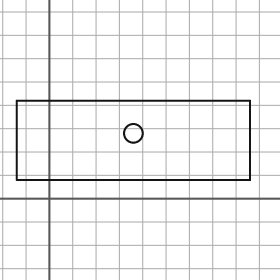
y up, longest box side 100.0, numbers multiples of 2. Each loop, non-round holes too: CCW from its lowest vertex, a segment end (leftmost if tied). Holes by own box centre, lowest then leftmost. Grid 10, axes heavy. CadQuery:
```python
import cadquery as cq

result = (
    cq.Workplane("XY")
    .moveTo(-14.0, 8.0)
    .lineTo(86.0, 8.0)
    .lineTo(86.0, 42.0)
    .lineTo(-14.0, 42.0)
    .close()
    .moveTo(36.0, 28.0)
    .circle(4.0)
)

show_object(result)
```